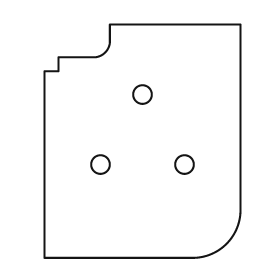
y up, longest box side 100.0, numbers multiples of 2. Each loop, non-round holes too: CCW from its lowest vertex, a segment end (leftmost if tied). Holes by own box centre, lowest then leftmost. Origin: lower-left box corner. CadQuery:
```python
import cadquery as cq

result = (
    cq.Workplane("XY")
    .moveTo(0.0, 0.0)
    .lineTo(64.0, 0.0)
    .threePointArc((78.0, 6.0), (84.0, 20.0))
    .lineTo(84.0, 100.0)
    .lineTo(28.0, 100.0)
    .lineTo(28.0, 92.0)
    .threePointArc((26.0, 88.0), (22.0, 86.0))
    .lineTo(6.0, 86.0)
    .lineTo(6.0, 80.0)
    .lineTo(0.0, 80.0)
    .close()
    .moveTo(24.0, 40.0)
    .circle(4.0)
    .moveTo(60.0, 40.0)
    .circle(4.0)
    .moveTo(42.0, 70.0)
    .circle(4.0)
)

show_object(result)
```